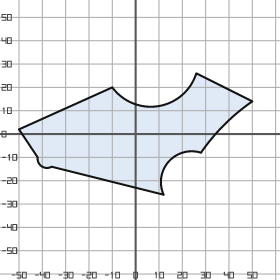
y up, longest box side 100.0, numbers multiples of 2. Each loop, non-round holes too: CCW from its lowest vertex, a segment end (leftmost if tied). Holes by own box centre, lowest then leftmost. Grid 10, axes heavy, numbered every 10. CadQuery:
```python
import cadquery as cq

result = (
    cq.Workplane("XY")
    .moveTo(12.0, -26.0)
    .threePointArc((14.0, -12.0), (28.0, -8.0))
    .threePointArc((38.0, 4.0), (50.0, 14.0))
    .lineTo(26.0, 26.0)
    .threePointArc((10.0, 12.0), (-10.0, 20.0))
    .lineTo(-50.0, 2.0)
    .lineTo(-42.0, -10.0)
    .threePointArc((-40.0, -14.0), (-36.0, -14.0))
    .close()
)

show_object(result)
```